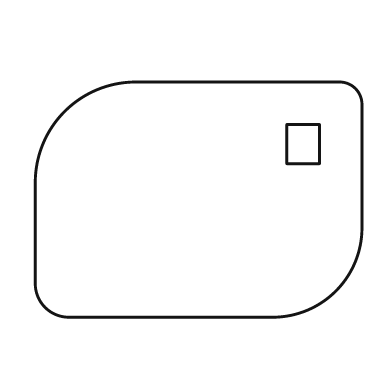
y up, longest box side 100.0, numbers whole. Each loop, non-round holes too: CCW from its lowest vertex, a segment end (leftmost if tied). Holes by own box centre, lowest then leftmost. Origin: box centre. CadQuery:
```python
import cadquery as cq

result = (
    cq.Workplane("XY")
    .moveTo(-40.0, -36.0)
    .lineTo(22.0, -36.0)
    .threePointArc((42.0, -28.0), (50.0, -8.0))
    .lineTo(50.0, 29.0)
    .threePointArc((48.0, 34.0), (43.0, 36.0))
    .lineTo(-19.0, 36.0)
    .threePointArc((-41.0, 27.0), (-50.0, 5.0))
    .lineTo(-50.0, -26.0)
    .threePointArc((-47.0, -33.0), (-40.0, -36.0))
    .close()
    .moveTo(27.0, 11.0)
    .lineTo(37.0, 11.0)
    .lineTo(37.0, 23.0)
    .lineTo(27.0, 23.0)
    .close()
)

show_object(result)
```